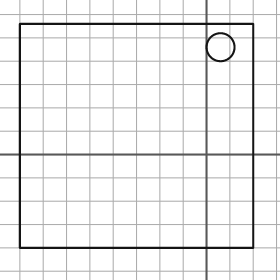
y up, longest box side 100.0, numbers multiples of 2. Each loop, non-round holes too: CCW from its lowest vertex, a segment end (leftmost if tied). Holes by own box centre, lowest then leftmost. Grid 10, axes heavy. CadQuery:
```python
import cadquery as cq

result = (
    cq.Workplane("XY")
    .moveTo(-80.0, -40.0)
    .lineTo(20.0, -40.0)
    .lineTo(20.0, 56.0)
    .lineTo(-80.0, 56.0)
    .close()
    .moveTo(6.0, 46.0)
    .circle(6.0)
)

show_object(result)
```